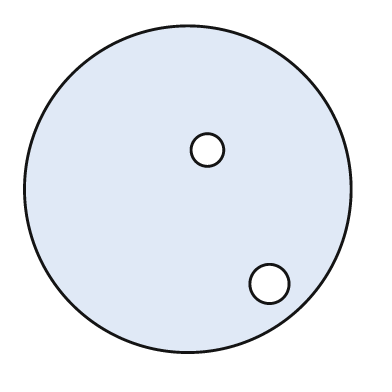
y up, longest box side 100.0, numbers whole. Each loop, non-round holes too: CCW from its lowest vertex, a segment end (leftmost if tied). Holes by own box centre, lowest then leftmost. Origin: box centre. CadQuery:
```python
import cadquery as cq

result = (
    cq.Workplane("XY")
    .moveTo(0.0, 0.0)
    .circle(50.0)
    .moveTo(25.0, -29.0)
    .circle(6.0)
    .moveTo(6.0, 12.0)
    .circle(5.0)
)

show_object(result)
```